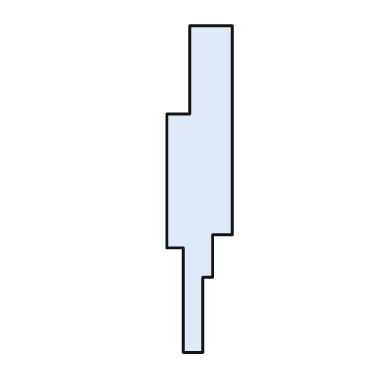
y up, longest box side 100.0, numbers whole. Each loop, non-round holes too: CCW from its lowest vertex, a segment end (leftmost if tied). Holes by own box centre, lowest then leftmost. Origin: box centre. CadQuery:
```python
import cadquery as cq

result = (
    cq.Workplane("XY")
    .moveTo(-5.0, -50.0)
    .lineTo(1.0, -50.0)
    .lineTo(1.0, -27.0)
    .lineTo(4.0, -27.0)
    .lineTo(4.0, -14.0)
    .lineTo(10.0, -14.0)
    .lineTo(10.0, 50.0)
    .lineTo(-3.0, 50.0)
    .lineTo(-3.0, 23.0)
    .lineTo(-10.0, 23.0)
    .lineTo(-10.0, -18.0)
    .lineTo(-5.0, -18.0)
    .close()
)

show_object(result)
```